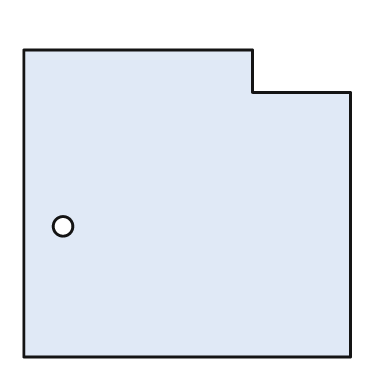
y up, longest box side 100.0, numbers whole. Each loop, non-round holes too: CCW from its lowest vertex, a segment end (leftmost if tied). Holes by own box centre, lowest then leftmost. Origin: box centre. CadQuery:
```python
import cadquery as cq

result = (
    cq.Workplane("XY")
    .moveTo(-50.0, -47.0)
    .lineTo(50.0, -47.0)
    .lineTo(50.0, 34.0)
    .lineTo(20.0, 34.0)
    .lineTo(20.0, 47.0)
    .lineTo(-50.0, 47.0)
    .close()
    .moveTo(-38.0, -7.0)
    .circle(3.0)
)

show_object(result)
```